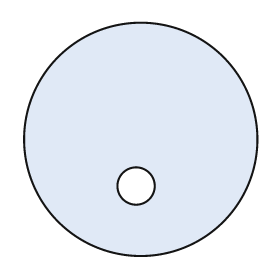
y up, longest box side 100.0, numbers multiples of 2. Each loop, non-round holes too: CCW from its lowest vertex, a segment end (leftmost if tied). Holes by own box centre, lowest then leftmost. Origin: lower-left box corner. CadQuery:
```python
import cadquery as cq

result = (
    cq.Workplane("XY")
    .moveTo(50.0, 50.0)
    .circle(50.0)
    .moveTo(48.0, 30.0)
    .circle(8.0)
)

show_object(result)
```